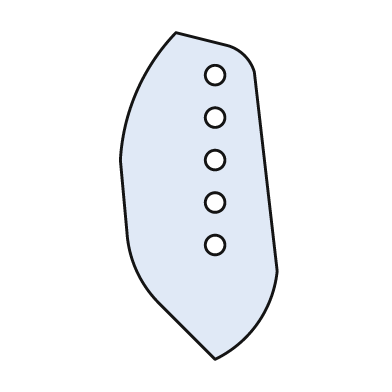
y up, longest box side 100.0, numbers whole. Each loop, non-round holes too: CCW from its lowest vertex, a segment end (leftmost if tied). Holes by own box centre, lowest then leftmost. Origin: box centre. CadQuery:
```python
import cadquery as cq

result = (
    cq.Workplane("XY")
    .moveTo(5.0, -50.0)
    .threePointArc((18.0, -39.0), (24.0, -23.0))
    .lineTo(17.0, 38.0)
    .threePointArc((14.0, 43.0), (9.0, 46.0))
    .lineTo(-7.0, 50.0)
    .threePointArc((-19.0, 32.0), (-24.0, 11.0))
    .lineTo(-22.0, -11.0)
    .threePointArc((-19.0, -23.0), (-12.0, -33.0))
    .close()
    .moveTo(5.0, -15.0)
    .circle(3.0)
    .moveTo(5.0, -2.0)
    .circle(3.0)
    .moveTo(5.0, 11.0)
    .circle(3.0)
    .moveTo(5.0, 24.0)
    .circle(3.0)
    .moveTo(5.0, 37.0)
    .circle(3.0)
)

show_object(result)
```